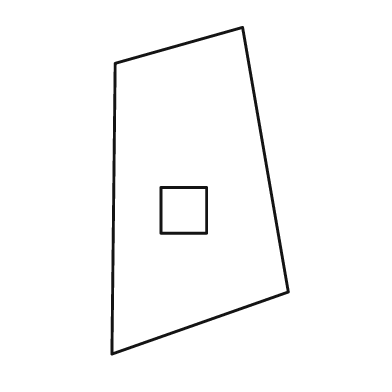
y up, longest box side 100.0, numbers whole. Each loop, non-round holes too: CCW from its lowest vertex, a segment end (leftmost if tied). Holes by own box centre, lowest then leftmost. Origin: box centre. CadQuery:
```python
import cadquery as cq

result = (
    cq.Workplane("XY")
    .moveTo(-27.0, -50.0)
    .lineTo(27.0, -31.0)
    .lineTo(13.0, 50.0)
    .lineTo(-26.0, 39.0)
    .close()
    .moveTo(-12.0, -13.0)
    .lineTo(2.0, -13.0)
    .lineTo(2.0, 1.0)
    .lineTo(-12.0, 1.0)
    .close()
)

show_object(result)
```